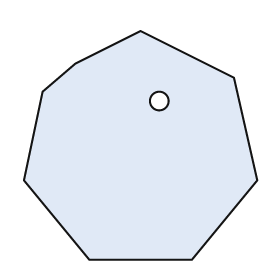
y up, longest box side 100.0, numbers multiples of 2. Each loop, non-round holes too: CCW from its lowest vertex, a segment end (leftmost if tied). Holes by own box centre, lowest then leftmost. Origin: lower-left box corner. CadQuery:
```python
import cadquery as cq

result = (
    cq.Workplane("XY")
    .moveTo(28.0, 0.0)
    .lineTo(72.0, 0.0)
    .lineTo(100.0, 34.0)
    .lineTo(90.0, 78.0)
    .lineTo(50.0, 98.0)
    .lineTo(22.0, 84.0)
    .lineTo(8.0, 72.0)
    .lineTo(0.0, 34.0)
    .close()
    .moveTo(58.0, 68.0)
    .circle(4.0)
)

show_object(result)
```